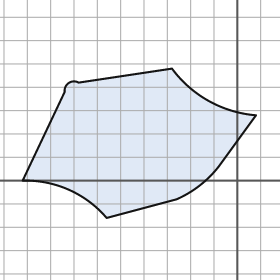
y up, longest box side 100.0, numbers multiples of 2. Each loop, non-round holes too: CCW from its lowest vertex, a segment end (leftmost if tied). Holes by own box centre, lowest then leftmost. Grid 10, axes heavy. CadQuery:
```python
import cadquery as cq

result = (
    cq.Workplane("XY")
    .moveTo(-56.0, -16.0)
    .lineTo(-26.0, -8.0)
    .threePointArc((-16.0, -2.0), (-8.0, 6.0))
    .lineTo(8.0, 28.0)
    .threePointArc((-12.0, 34.0), (-28.0, 48.0))
    .lineTo(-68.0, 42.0)
    .threePointArc((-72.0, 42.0), (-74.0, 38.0))
    .lineTo(-92.0, 0.0)
    .threePointArc((-72.0, -4.0), (-56.0, -16.0))
    .close()
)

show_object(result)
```